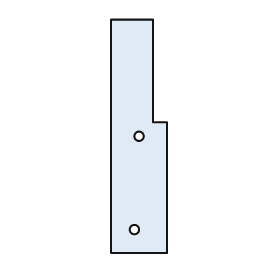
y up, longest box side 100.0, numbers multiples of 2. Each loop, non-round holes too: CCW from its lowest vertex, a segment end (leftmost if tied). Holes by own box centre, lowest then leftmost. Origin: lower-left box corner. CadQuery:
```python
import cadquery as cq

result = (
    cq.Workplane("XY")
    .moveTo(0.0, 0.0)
    .lineTo(24.0, 0.0)
    .lineTo(24.0, 56.0)
    .lineTo(18.0, 56.0)
    .lineTo(18.0, 100.0)
    .lineTo(0.0, 100.0)
    .close()
    .moveTo(10.0, 10.0)
    .circle(2.0)
    .moveTo(12.0, 50.0)
    .circle(2.0)
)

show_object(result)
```